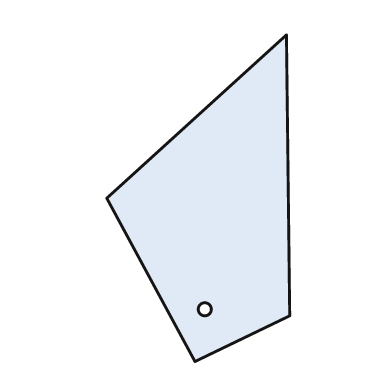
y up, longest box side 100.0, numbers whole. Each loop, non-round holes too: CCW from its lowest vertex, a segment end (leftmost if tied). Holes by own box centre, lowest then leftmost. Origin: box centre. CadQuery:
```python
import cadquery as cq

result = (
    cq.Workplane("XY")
    .moveTo(-1.0, -50.0)
    .lineTo(28.0, -36.0)
    .lineTo(27.0, 50.0)
    .lineTo(-28.0, 0.0)
    .close()
    .moveTo(2.0, -34.0)
    .circle(2.0)
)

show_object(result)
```